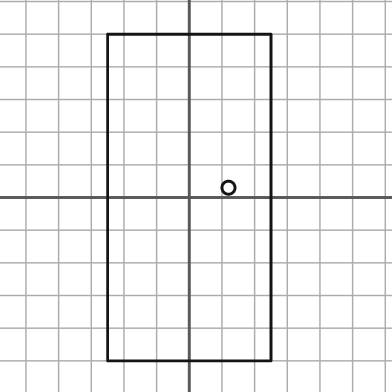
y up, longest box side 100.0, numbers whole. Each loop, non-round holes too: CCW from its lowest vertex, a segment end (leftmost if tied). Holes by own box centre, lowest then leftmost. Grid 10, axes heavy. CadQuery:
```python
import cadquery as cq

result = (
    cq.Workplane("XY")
    .moveTo(-25.0, -50.0)
    .lineTo(25.0, -50.0)
    .lineTo(25.0, 50.0)
    .lineTo(-25.0, 50.0)
    .close()
    .moveTo(12.0, 3.0)
    .circle(2.0)
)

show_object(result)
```